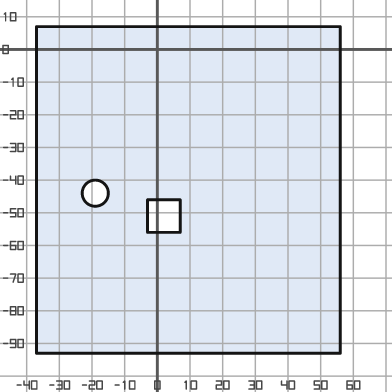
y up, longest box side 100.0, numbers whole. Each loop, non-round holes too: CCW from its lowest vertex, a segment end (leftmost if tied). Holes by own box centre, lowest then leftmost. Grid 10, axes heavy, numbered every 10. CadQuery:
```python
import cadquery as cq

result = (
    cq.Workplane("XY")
    .moveTo(-37.0, -93.0)
    .lineTo(56.0, -93.0)
    .lineTo(56.0, 7.0)
    .lineTo(-37.0, 7.0)
    .close()
    .moveTo(-3.0, -56.0)
    .lineTo(7.0, -56.0)
    .lineTo(7.0, -46.0)
    .lineTo(-3.0, -46.0)
    .close()
    .moveTo(-19.0, -44.0)
    .circle(4.0)
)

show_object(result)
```